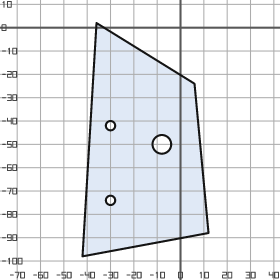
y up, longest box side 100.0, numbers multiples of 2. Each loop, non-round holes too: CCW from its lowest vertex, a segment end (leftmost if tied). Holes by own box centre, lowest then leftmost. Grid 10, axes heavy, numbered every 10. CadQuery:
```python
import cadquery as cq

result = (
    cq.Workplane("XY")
    .moveTo(-42.0, -98.0)
    .lineTo(12.0, -88.0)
    .lineTo(6.0, -24.0)
    .lineTo(-36.0, 2.0)
    .close()
    .moveTo(-30.0, -74.0)
    .circle(2.0)
    .moveTo(-8.0, -50.0)
    .circle(4.0)
    .moveTo(-30.0, -42.0)
    .circle(2.0)
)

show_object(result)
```